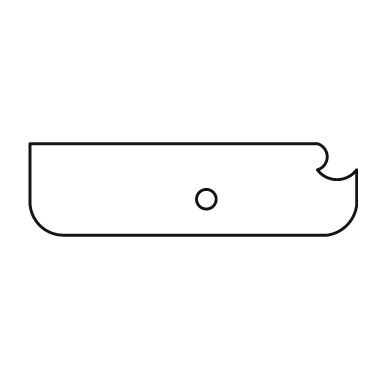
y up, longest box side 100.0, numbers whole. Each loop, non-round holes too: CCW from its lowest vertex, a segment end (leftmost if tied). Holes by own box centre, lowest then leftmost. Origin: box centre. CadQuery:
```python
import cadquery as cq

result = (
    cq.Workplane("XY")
    .moveTo(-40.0, -14.0)
    .lineTo(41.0, -14.0)
    .threePointArc((47.0, -11.0), (50.0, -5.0))
    .lineTo(50.0, 6.0)
    .threePointArc((44.0, 3.0), (38.0, 6.0))
    .threePointArc((41.0, 10.0), (38.0, 14.0))
    .lineTo(-50.0, 14.0)
    .lineTo(-50.0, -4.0)
    .threePointArc((-47.0, -11.0), (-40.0, -14.0))
    .close()
    .moveTo(4.0, -3.0)
    .circle(3.0)
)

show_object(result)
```